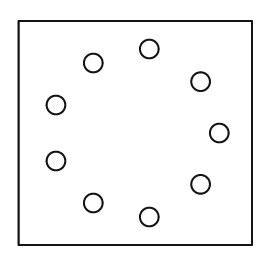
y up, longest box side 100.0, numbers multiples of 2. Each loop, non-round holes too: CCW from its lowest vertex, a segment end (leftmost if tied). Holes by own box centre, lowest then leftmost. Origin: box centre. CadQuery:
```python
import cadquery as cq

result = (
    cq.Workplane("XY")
    .moveTo(-50.0, -48.0)
    .lineTo(50.0, -48.0)
    .lineTo(50.0, 48.0)
    .lineTo(-50.0, 48.0)
    .close()
    .moveTo(6.0, -36.0)
    .circle(4.0)
    .moveTo(-18.0, -30.0)
    .circle(4.0)
    .moveTo(28.0, -22.0)
    .circle(4.0)
    .moveTo(-34.0, -12.0)
    .circle(4.0)
    .moveTo(36.0, 0.0)
    .circle(4.0)
    .moveTo(-34.0, 12.0)
    .circle(4.0)
    .moveTo(28.0, 22.0)
    .circle(4.0)
    .moveTo(-18.0, 30.0)
    .circle(4.0)
    .moveTo(6.0, 36.0)
    .circle(4.0)
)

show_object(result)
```